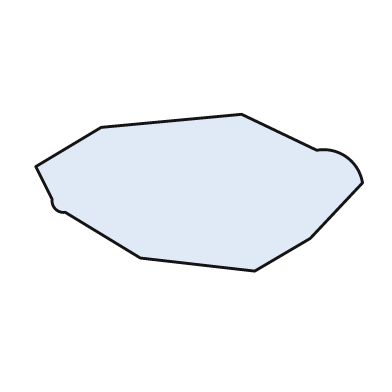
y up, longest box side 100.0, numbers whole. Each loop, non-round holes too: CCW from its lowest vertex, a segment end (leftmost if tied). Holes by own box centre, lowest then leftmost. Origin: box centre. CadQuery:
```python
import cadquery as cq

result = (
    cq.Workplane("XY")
    .moveTo(17.0, -24.0)
    .lineTo(34.0, -14.0)
    .lineTo(50.0, 3.0)
    .threePointArc((45.0, 11.0), (36.0, 13.0))
    .lineTo(13.0, 24.0)
    .lineTo(-30.0, 20.0)
    .lineTo(-50.0, 8.0)
    .lineTo(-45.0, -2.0)
    .threePointArc((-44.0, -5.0), (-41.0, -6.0))
    .lineTo(-18.0, -20.0)
    .close()
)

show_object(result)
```